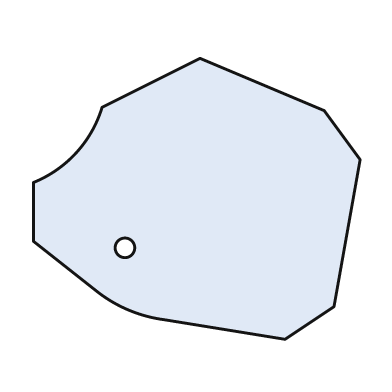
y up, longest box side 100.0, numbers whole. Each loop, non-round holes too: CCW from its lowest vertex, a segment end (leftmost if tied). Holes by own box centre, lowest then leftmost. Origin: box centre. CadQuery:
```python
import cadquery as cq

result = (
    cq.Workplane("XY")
    .moveTo(27.0, -43.0)
    .lineTo(42.0, -33.0)
    .lineTo(50.0, 12.0)
    .lineTo(39.0, 27.0)
    .lineTo(1.0, 43.0)
    .lineTo(-29.0, 28.0)
    .threePointArc((-37.0, 14.0), (-50.0, 5.0))
    .lineTo(-50.0, -13.0)
    .lineTo(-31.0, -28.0)
    .threePointArc((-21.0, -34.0), (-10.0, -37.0))
    .close()
    .moveTo(-22.0, -15.0)
    .circle(3.0)
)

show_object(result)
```